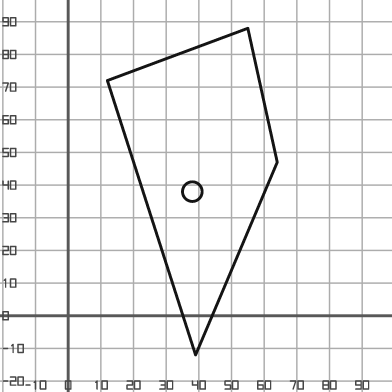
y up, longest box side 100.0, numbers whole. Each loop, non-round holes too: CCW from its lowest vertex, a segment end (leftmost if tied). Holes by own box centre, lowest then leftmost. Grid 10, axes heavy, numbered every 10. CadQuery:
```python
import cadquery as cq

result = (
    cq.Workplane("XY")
    .moveTo(39.0, -12.0)
    .lineTo(64.0, 47.0)
    .lineTo(55.0, 88.0)
    .lineTo(12.0, 72.0)
    .close()
    .moveTo(38.0, 38.0)
    .circle(3.0)
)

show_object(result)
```